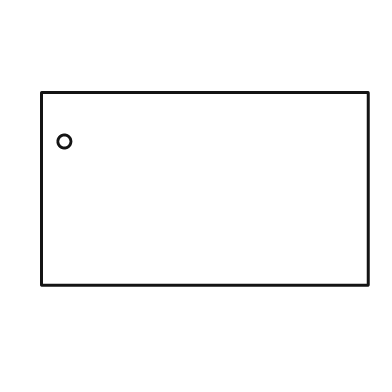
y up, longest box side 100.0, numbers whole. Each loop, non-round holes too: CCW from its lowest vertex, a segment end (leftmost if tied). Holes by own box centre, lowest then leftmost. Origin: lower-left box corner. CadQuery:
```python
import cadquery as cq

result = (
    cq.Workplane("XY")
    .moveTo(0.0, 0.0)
    .lineTo(100.0, 0.0)
    .lineTo(100.0, 59.0)
    .lineTo(0.0, 59.0)
    .close()
    .moveTo(7.0, 44.0)
    .circle(2.0)
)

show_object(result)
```